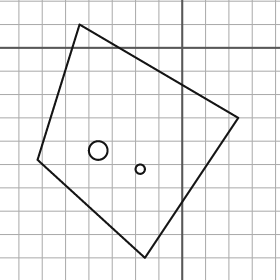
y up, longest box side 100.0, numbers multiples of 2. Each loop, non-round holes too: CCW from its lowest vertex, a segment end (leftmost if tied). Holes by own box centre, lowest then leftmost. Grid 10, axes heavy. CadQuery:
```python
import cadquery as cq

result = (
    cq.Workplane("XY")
    .moveTo(-16.0, -90.0)
    .lineTo(24.0, -30.0)
    .lineTo(-44.0, 10.0)
    .lineTo(-62.0, -48.0)
    .close()
    .moveTo(-18.0, -52.0)
    .circle(2.0)
    .moveTo(-36.0, -44.0)
    .circle(4.0)
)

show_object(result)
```